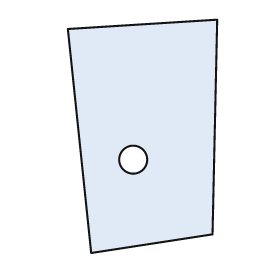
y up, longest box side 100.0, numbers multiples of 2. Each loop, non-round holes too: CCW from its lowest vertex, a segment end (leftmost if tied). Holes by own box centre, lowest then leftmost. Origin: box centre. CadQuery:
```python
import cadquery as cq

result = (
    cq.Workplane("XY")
    .moveTo(-22.0, -50.0)
    .lineTo(30.0, -42.0)
    .lineTo(32.0, 50.0)
    .lineTo(-32.0, 46.0)
    .close()
    .moveTo(-4.0, -10.0)
    .circle(6.0)
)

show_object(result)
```